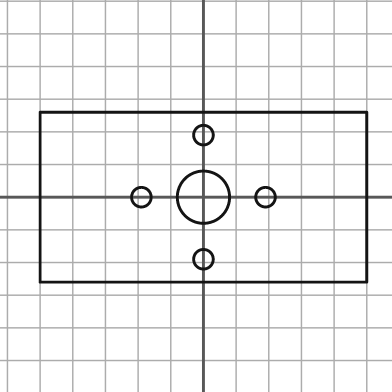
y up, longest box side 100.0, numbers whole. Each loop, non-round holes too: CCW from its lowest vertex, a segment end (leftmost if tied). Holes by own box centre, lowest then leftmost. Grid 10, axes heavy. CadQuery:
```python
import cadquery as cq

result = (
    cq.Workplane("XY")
    .moveTo(-50.0, -26.0)
    .lineTo(50.0, -26.0)
    .lineTo(50.0, 26.0)
    .lineTo(-50.0, 26.0)
    .close()
    .moveTo(0.0, -19.0)
    .circle(3.0)
    .moveTo(-19.0, 0.0)
    .circle(3.0)
    .moveTo(0.0, 0.0)
    .circle(8.0)
    .moveTo(19.0, 0.0)
    .circle(3.0)
    .moveTo(0.0, 19.0)
    .circle(3.0)
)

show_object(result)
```